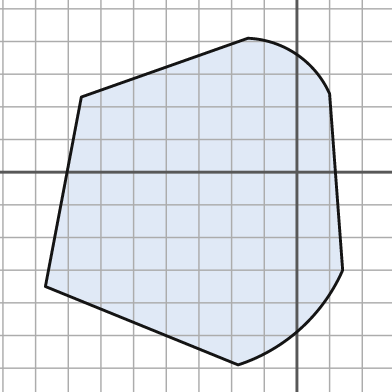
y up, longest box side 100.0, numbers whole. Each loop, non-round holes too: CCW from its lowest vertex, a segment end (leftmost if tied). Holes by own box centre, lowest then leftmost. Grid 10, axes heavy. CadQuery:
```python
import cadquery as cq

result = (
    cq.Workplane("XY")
    .moveTo(-18.0, -59.0)
    .threePointArc((1.0, -48.0), (14.0, -30.0))
    .lineTo(10.0, 24.0)
    .threePointArc((0.0, 36.0), (-15.0, 41.0))
    .lineTo(-66.0, 23.0)
    .lineTo(-77.0, -35.0)
    .close()
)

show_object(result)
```